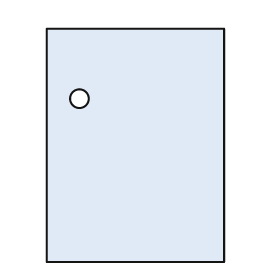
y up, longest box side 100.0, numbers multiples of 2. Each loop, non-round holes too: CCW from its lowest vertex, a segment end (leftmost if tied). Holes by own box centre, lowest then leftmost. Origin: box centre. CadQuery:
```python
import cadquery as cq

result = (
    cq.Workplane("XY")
    .moveTo(-38.0, -50.0)
    .lineTo(38.0, -50.0)
    .lineTo(38.0, 50.0)
    .lineTo(-38.0, 50.0)
    .close()
    .moveTo(-24.0, 20.0)
    .circle(4.0)
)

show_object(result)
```